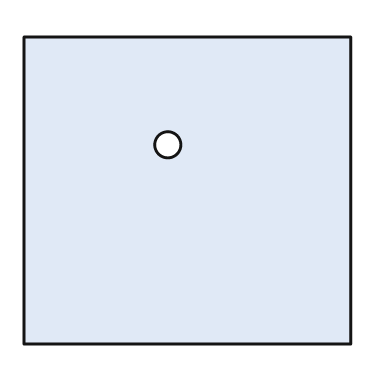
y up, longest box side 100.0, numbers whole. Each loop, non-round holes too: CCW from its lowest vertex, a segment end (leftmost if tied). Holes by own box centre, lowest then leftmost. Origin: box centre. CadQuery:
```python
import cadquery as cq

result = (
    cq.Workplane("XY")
    .moveTo(-50.0, -47.0)
    .lineTo(50.0, -47.0)
    .lineTo(50.0, 47.0)
    .lineTo(-50.0, 47.0)
    .close()
    .moveTo(-6.0, 14.0)
    .circle(4.0)
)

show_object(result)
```